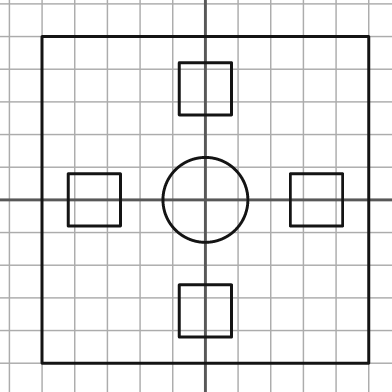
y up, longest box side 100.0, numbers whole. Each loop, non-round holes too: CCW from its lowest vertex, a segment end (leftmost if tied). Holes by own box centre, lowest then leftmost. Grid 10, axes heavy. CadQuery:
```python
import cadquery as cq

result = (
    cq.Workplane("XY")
    .moveTo(-50.0, -50.0)
    .lineTo(50.0, -50.0)
    .lineTo(50.0, 50.0)
    .lineTo(-50.0, 50.0)
    .close()
    .moveTo(-8.0, -42.0)
    .lineTo(8.0, -42.0)
    .lineTo(8.0, -26.0)
    .lineTo(-8.0, -26.0)
    .close()
    .moveTo(-42.0, -8.0)
    .lineTo(-26.0, -8.0)
    .lineTo(-26.0, 8.0)
    .lineTo(-42.0, 8.0)
    .close()
    .moveTo(0.0, 0.0)
    .circle(13.0)
    .moveTo(26.0, -8.0)
    .lineTo(42.0, -8.0)
    .lineTo(42.0, 8.0)
    .lineTo(26.0, 8.0)
    .close()
    .moveTo(-8.0, 26.0)
    .lineTo(8.0, 26.0)
    .lineTo(8.0, 42.0)
    .lineTo(-8.0, 42.0)
    .close()
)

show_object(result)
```